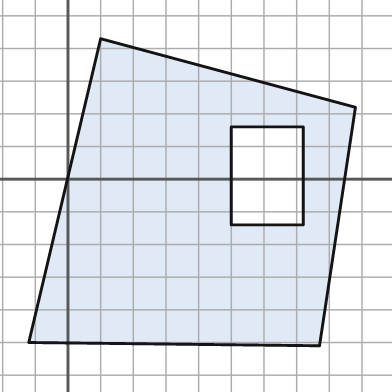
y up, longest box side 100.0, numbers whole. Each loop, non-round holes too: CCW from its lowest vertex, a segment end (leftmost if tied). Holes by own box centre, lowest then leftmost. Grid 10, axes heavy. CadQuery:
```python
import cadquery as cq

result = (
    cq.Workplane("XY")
    .moveTo(77.0, -51.0)
    .lineTo(88.0, 22.0)
    .lineTo(10.0, 43.0)
    .lineTo(-12.0, -50.0)
    .close()
    .moveTo(50.0, -14.0)
    .lineTo(72.0, -14.0)
    .lineTo(72.0, 16.0)
    .lineTo(50.0, 16.0)
    .close()
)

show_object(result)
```